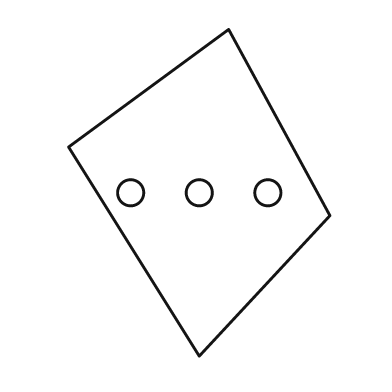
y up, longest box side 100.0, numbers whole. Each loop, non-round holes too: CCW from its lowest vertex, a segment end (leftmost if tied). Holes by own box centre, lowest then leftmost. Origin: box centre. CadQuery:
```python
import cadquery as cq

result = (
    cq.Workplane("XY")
    .moveTo(0.0, -50.0)
    .lineTo(40.0, -7.0)
    .lineTo(9.0, 50.0)
    .lineTo(-40.0, 14.0)
    .close()
    .moveTo(-21.0, 0.0)
    .circle(4.0)
    .moveTo(0.0, 0.0)
    .circle(4.0)
    .moveTo(21.0, 0.0)
    .circle(4.0)
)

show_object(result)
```